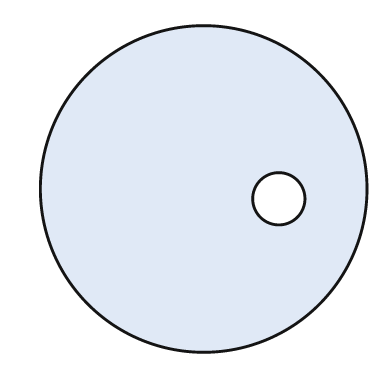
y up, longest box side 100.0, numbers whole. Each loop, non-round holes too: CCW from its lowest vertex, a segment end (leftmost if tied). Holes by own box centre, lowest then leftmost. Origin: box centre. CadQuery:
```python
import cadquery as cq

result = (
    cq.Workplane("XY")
    .moveTo(0.0, 0.0)
    .circle(50.0)
    .moveTo(23.0, -3.0)
    .circle(8.0)
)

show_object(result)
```